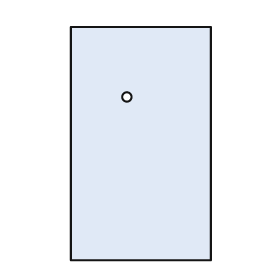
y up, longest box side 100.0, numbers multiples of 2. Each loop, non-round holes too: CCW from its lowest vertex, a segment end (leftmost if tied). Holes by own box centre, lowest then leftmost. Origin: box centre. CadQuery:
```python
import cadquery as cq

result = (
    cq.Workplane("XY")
    .moveTo(-30.0, -50.0)
    .lineTo(30.0, -50.0)
    .lineTo(30.0, 50.0)
    .lineTo(-30.0, 50.0)
    .close()
    .moveTo(-6.0, 20.0)
    .circle(2.0)
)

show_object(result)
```